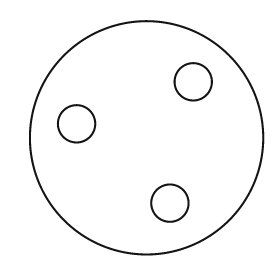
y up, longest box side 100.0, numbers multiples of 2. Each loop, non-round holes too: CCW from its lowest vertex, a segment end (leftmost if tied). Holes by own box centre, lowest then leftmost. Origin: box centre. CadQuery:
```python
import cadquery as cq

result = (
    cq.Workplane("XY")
    .moveTo(0.0, 0.0)
    .circle(50.0)
    .moveTo(10.0, -28.0)
    .circle(8.0)
    .moveTo(-30.0, 6.0)
    .circle(8.0)
    .moveTo(20.0, 24.0)
    .circle(8.0)
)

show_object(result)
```